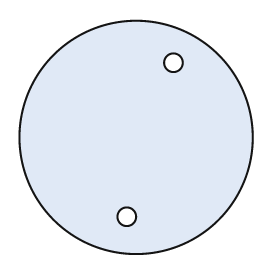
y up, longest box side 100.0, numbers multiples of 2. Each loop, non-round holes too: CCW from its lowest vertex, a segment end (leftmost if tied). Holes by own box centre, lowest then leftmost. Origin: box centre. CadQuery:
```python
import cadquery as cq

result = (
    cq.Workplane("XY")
    .moveTo(0.0, 0.0)
    .circle(50.0)
    .moveTo(-4.0, -34.0)
    .circle(4.0)
    .moveTo(16.0, 32.0)
    .circle(4.0)
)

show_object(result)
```